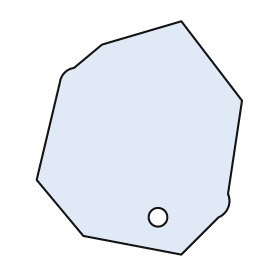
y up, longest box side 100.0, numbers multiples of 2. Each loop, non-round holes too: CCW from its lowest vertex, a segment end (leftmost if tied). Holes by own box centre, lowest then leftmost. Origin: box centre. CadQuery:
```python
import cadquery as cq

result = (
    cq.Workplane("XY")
    .moveTo(18.0, -50.0)
    .lineTo(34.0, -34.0)
    .threePointArc((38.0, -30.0), (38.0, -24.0))
    .lineTo(44.0, 16.0)
    .lineTo(18.0, 50.0)
    .lineTo(-16.0, 40.0)
    .lineTo(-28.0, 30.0)
    .threePointArc((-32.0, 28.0), (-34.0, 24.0))
    .lineTo(-44.0, -18.0)
    .lineTo(-24.0, -42.0)
    .close()
    .moveTo(8.0, -34.0)
    .circle(4.0)
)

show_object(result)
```